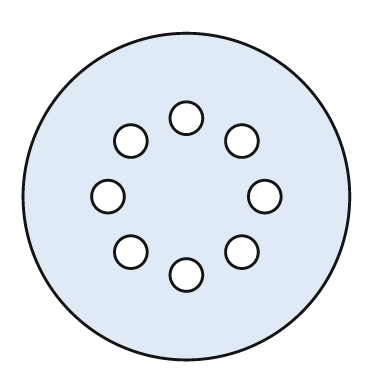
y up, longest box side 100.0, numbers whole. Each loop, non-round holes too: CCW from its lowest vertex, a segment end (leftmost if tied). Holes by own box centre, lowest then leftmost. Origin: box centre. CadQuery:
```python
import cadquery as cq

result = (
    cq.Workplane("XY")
    .moveTo(0.0, 0.0)
    .circle(50.0)
    .moveTo(0.0, -24.0)
    .circle(5.0)
    .moveTo(-17.0, -17.0)
    .circle(5.0)
    .moveTo(17.0, -17.0)
    .circle(5.0)
    .moveTo(-24.0, 0.0)
    .circle(5.0)
    .moveTo(24.0, 0.0)
    .circle(5.0)
    .moveTo(-17.0, 17.0)
    .circle(5.0)
    .moveTo(17.0, 17.0)
    .circle(5.0)
    .moveTo(0.0, 24.0)
    .circle(5.0)
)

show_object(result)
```